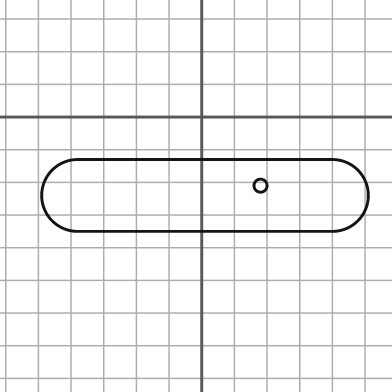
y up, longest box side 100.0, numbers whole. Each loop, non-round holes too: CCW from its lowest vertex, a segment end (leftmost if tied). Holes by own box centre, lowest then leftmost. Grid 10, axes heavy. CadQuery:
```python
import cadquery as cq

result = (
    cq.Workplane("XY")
    .moveTo(-38.0, -35.0)
    .lineTo(40.0, -35.0)
    .threePointArc((51.0, -24.0), (40.0, -13.0))
    .lineTo(-38.0, -13.0)
    .threePointArc((-49.0, -24.0), (-38.0, -35.0))
    .close()
    .moveTo(18.0, -21.0)
    .circle(2.0)
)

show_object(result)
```